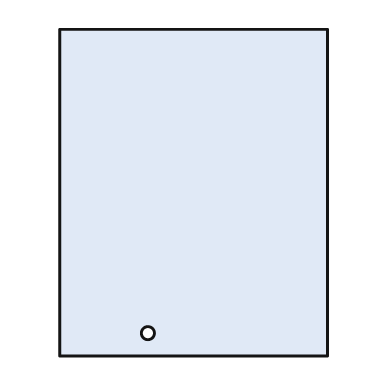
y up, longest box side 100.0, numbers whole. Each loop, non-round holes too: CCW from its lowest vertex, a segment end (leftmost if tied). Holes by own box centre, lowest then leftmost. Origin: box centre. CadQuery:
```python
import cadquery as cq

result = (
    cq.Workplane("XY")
    .moveTo(-41.0, -50.0)
    .lineTo(41.0, -50.0)
    .lineTo(41.0, 50.0)
    .lineTo(-41.0, 50.0)
    .close()
    .moveTo(-14.0, -43.0)
    .circle(2.0)
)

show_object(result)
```